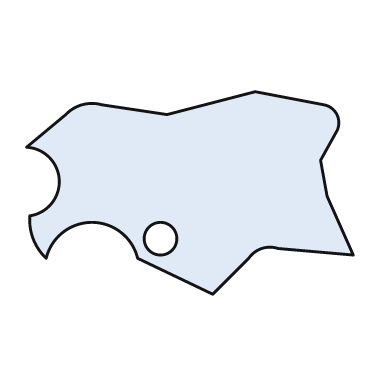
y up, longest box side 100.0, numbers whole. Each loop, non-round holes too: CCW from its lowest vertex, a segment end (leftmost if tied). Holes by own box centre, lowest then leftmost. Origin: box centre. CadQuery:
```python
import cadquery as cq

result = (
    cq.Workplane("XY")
    .moveTo(7.0, -31.0)
    .lineTo(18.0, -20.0)
    .threePointArc((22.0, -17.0), (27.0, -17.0))
    .lineTo(50.0, -19.0)
    .lineTo(42.0, -1.0)
    .lineTo(40.0, 10.0)
    .lineTo(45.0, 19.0)
    .threePointArc((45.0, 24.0), (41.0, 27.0))
    .lineTo(20.0, 31.0)
    .lineTo(-7.0, 24.0)
    .lineTo(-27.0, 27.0)
    .threePointArc((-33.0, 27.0), (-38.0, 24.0))
    .lineTo(-50.0, 14.0)
    .threePointArc((-40.0, 4.0), (-49.0, -7.0))
    .threePointArc((-48.0, -14.0), (-44.0, -20.0))
    .threePointArc((-30.0, -9.0), (-16.0, -20.0))
    .close()
    .moveTo(-9.0, -14.0)
    .circle(5.0)
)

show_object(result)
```